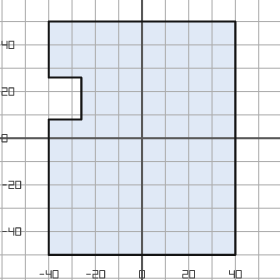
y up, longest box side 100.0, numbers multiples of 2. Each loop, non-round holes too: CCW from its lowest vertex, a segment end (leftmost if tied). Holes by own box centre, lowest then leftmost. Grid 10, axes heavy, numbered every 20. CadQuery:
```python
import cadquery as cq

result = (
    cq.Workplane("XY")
    .moveTo(-40.0, -50.0)
    .lineTo(40.0, -50.0)
    .lineTo(40.0, 50.0)
    .lineTo(-40.0, 50.0)
    .lineTo(-40.0, 26.0)
    .lineTo(-26.0, 26.0)
    .lineTo(-26.0, 8.0)
    .lineTo(-40.0, 8.0)
    .close()
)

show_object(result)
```